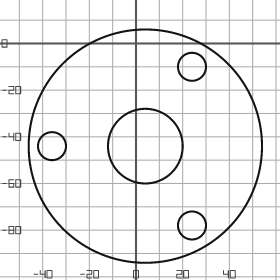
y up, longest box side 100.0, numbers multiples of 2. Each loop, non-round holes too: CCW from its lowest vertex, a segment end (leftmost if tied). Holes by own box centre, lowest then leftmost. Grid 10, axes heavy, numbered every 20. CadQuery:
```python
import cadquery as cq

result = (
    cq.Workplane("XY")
    .moveTo(4.0, -44.0)
    .circle(50.0)
    .moveTo(24.0, -78.0)
    .circle(6.0)
    .moveTo(-36.0, -44.0)
    .circle(6.0)
    .moveTo(4.0, -44.0)
    .circle(16.0)
    .moveTo(24.0, -10.0)
    .circle(6.0)
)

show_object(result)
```